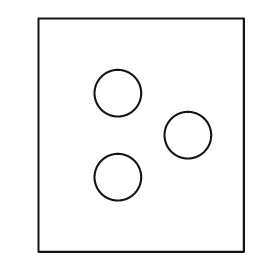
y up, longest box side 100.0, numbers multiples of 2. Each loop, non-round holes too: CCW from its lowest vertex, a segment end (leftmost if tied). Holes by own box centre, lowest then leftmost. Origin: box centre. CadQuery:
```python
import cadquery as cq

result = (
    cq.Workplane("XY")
    .moveTo(-44.0, -50.0)
    .lineTo(44.0, -50.0)
    .lineTo(44.0, 50.0)
    .lineTo(-44.0, 50.0)
    .close()
    .moveTo(-10.0, -18.0)
    .circle(10.0)
    .moveTo(20.0, 0.0)
    .circle(10.0)
    .moveTo(-10.0, 18.0)
    .circle(10.0)
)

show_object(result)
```